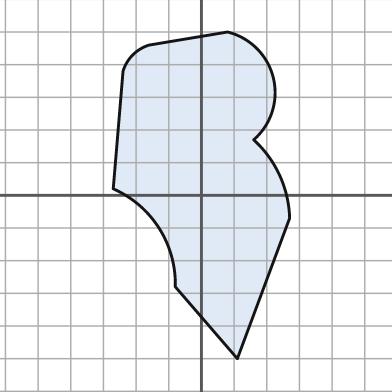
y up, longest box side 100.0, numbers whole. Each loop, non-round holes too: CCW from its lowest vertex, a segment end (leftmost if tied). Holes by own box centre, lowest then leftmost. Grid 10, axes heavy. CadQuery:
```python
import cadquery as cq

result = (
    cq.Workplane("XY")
    .moveTo(11.0, -50.0)
    .lineTo(27.0, -7.0)
    .threePointArc((24.0, 6.0), (16.0, 17.0))
    .threePointArc((22.0, 36.0), (8.0, 50.0))
    .lineTo(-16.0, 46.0)
    .threePointArc((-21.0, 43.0), (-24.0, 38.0))
    .lineTo(-27.0, 2.0)
    .threePointArc((-13.0, -10.0), (-8.0, -28.0))
    .close()
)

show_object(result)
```